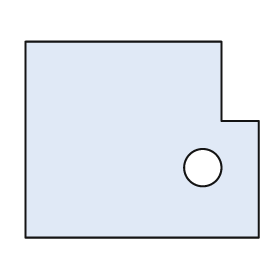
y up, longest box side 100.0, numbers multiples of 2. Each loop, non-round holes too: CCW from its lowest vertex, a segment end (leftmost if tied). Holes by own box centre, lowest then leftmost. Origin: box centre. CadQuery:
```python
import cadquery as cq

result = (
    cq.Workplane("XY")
    .moveTo(-50.0, -42.0)
    .lineTo(50.0, -42.0)
    .lineTo(50.0, 8.0)
    .lineTo(34.0, 8.0)
    .lineTo(34.0, 42.0)
    .lineTo(-50.0, 42.0)
    .close()
    .moveTo(26.0, -12.0)
    .circle(8.0)
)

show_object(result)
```